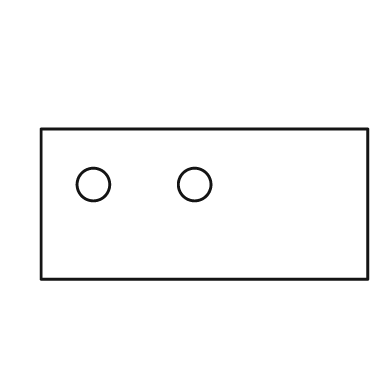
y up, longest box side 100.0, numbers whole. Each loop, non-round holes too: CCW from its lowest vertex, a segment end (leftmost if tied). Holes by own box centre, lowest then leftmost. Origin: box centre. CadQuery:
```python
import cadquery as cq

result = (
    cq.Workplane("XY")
    .moveTo(-50.0, -23.0)
    .lineTo(50.0, -23.0)
    .lineTo(50.0, 23.0)
    .lineTo(-50.0, 23.0)
    .close()
    .moveTo(-34.0, 6.0)
    .circle(5.0)
    .moveTo(-3.0, 6.0)
    .circle(5.0)
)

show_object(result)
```